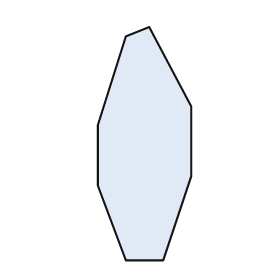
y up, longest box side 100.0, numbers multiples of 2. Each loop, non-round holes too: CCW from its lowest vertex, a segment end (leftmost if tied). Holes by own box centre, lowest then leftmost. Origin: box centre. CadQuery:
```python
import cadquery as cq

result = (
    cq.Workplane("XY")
    .moveTo(-8.0, -50.0)
    .lineTo(8.0, -50.0)
    .lineTo(20.0, -14.0)
    .lineTo(20.0, 16.0)
    .lineTo(2.0, 50.0)
    .lineTo(-8.0, 46.0)
    .lineTo(-20.0, 8.0)
    .lineTo(-20.0, -18.0)
    .close()
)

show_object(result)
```